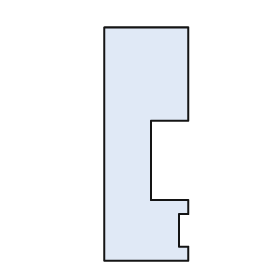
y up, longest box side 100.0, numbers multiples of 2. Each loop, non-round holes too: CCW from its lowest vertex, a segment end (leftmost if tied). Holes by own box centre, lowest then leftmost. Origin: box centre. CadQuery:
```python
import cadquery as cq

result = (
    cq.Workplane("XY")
    .moveTo(-18.0, -50.0)
    .lineTo(18.0, -50.0)
    .lineTo(18.0, -44.0)
    .lineTo(14.0, -44.0)
    .lineTo(14.0, -30.0)
    .lineTo(18.0, -30.0)
    .lineTo(18.0, -24.0)
    .lineTo(2.0, -24.0)
    .lineTo(2.0, 10.0)
    .lineTo(18.0, 10.0)
    .lineTo(18.0, 50.0)
    .lineTo(-18.0, 50.0)
    .close()
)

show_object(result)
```